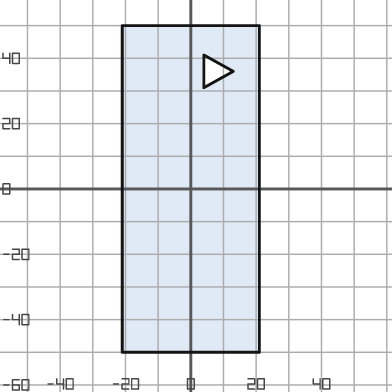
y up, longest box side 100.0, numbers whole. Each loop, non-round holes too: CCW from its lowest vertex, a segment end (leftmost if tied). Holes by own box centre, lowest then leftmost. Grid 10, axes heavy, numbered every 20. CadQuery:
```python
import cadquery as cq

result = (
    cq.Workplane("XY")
    .moveTo(-21.0, -50.0)
    .lineTo(21.0, -50.0)
    .lineTo(21.0, 50.0)
    .lineTo(-21.0, 50.0)
    .close()
    .moveTo(4.0, 31.0)
    .lineTo(13.0, 36.0)
    .lineTo(4.0, 41.0)
    .close()
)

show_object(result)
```